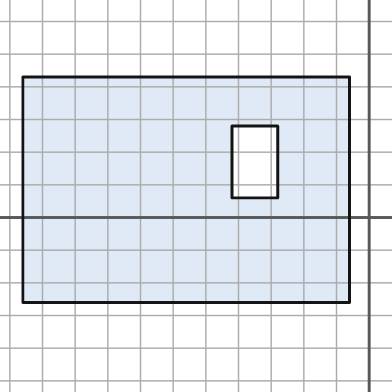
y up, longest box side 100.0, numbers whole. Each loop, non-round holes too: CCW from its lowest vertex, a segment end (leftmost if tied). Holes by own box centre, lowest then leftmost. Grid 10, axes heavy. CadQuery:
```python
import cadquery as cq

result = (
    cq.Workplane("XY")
    .moveTo(-106.0, -26.0)
    .lineTo(-6.0, -26.0)
    .lineTo(-6.0, 43.0)
    .lineTo(-106.0, 43.0)
    .close()
    .moveTo(-42.0, 6.0)
    .lineTo(-28.0, 6.0)
    .lineTo(-28.0, 28.0)
    .lineTo(-42.0, 28.0)
    .close()
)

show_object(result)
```